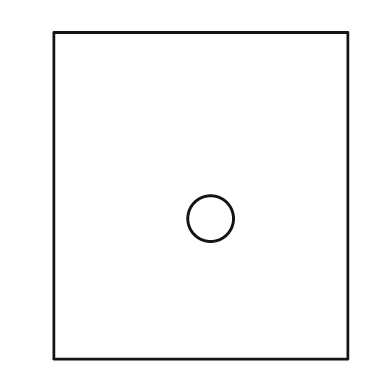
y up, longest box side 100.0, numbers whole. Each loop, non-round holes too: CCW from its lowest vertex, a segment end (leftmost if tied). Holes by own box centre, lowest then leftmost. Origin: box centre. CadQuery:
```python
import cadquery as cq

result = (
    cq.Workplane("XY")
    .moveTo(-45.0, -50.0)
    .lineTo(45.0, -50.0)
    .lineTo(45.0, 50.0)
    .lineTo(-45.0, 50.0)
    .close()
    .moveTo(3.0, -7.0)
    .circle(7.0)
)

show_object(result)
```